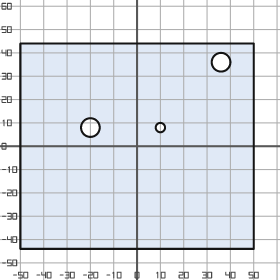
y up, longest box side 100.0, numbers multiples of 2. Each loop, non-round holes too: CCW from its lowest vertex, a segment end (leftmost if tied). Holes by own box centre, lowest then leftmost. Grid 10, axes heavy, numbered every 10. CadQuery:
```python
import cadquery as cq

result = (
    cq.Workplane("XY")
    .moveTo(-50.0, -44.0)
    .lineTo(50.0, -44.0)
    .lineTo(50.0, 44.0)
    .lineTo(-50.0, 44.0)
    .close()
    .moveTo(-20.0, 8.0)
    .circle(4.0)
    .moveTo(10.0, 8.0)
    .circle(2.0)
    .moveTo(36.0, 36.0)
    .circle(4.0)
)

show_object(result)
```